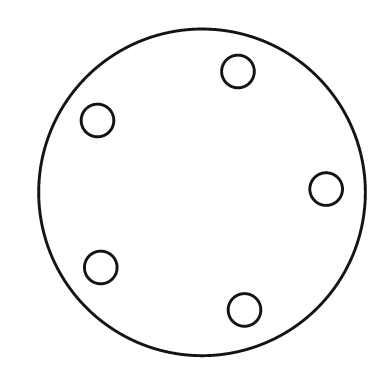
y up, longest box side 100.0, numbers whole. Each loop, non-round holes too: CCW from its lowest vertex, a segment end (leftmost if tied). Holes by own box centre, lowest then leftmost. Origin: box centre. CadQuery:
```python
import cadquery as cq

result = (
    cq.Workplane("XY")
    .moveTo(0.0, 0.0)
    .circle(50.0)
    .moveTo(13.0, -36.0)
    .circle(5.0)
    .moveTo(-31.0, -23.0)
    .circle(5.0)
    .moveTo(38.0, 1.0)
    .circle(5.0)
    .moveTo(-32.0, 22.0)
    .circle(5.0)
    .moveTo(11.0, 37.0)
    .circle(5.0)
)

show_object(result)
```